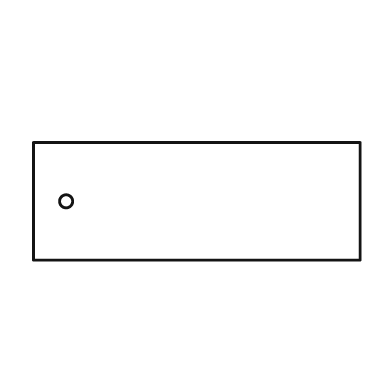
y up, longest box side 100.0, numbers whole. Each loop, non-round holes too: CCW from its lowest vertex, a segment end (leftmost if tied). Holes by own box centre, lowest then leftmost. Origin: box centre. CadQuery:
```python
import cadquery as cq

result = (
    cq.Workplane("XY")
    .moveTo(-50.0, -18.0)
    .lineTo(50.0, -18.0)
    .lineTo(50.0, 18.0)
    .lineTo(-50.0, 18.0)
    .close()
    .moveTo(-40.0, 0.0)
    .circle(2.0)
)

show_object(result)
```